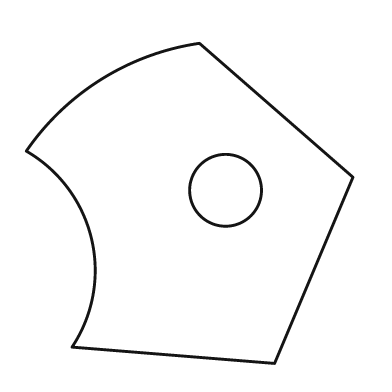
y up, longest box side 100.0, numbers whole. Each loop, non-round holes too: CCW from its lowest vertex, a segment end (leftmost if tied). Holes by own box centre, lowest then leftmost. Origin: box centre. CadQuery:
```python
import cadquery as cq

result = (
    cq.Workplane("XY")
    .moveTo(26.0, -49.0)
    .lineTo(50.0, 8.0)
    .lineTo(3.0, 49.0)
    .threePointArc((-27.0, 38.0), (-50.0, 16.0))
    .threePointArc((-30.0, -11.0), (-36.0, -44.0))
    .close()
    .moveTo(11.0, 4.0)
    .circle(11.0)
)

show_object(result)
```